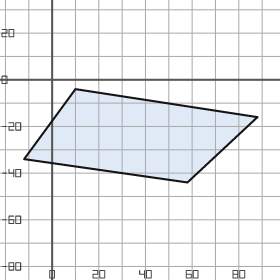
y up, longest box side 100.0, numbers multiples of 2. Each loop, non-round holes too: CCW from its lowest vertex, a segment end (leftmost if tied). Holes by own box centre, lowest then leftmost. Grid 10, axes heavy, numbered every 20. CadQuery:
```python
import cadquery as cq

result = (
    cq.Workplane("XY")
    .moveTo(58.0, -44.0)
    .lineTo(88.0, -16.0)
    .lineTo(10.0, -4.0)
    .lineTo(-12.0, -34.0)
    .close()
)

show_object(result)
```